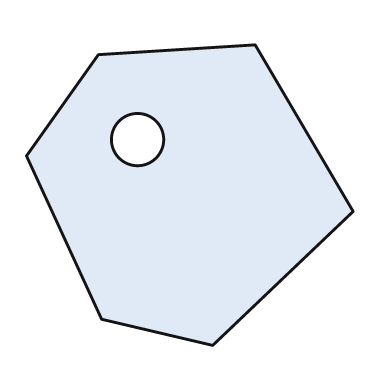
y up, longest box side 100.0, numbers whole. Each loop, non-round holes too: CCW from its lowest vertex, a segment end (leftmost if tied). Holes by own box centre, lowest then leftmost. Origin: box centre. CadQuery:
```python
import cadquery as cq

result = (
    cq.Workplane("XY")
    .moveTo(7.0, -46.0)
    .lineTo(50.0, -5.0)
    .lineTo(20.0, 46.0)
    .lineTo(-28.0, 43.0)
    .lineTo(-50.0, 12.0)
    .lineTo(-27.0, -38.0)
    .close()
    .moveTo(-16.0, 17.0)
    .circle(8.0)
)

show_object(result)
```